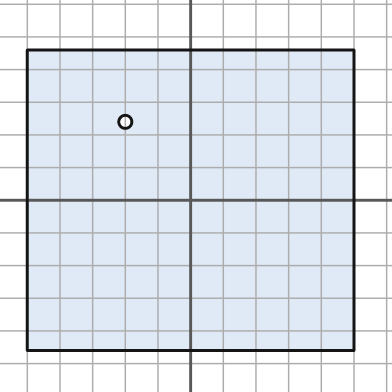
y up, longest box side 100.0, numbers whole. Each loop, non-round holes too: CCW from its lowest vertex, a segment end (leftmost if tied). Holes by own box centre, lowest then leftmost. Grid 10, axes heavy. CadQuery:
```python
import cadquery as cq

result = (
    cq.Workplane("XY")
    .moveTo(-50.0, -46.0)
    .lineTo(50.0, -46.0)
    .lineTo(50.0, 46.0)
    .lineTo(-50.0, 46.0)
    .close()
    .moveTo(-20.0, 24.0)
    .circle(2.0)
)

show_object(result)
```